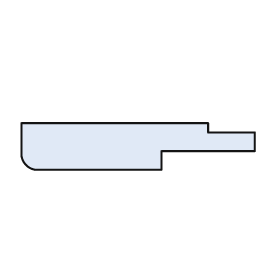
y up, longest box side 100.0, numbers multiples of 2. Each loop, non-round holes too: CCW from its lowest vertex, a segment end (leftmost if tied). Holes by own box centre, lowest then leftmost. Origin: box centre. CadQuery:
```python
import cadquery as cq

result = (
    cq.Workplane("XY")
    .moveTo(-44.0, -10.0)
    .lineTo(10.0, -10.0)
    .lineTo(10.0, -2.0)
    .lineTo(50.0, -2.0)
    .lineTo(50.0, 6.0)
    .lineTo(30.0, 6.0)
    .lineTo(30.0, 10.0)
    .lineTo(-50.0, 10.0)
    .lineTo(-50.0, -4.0)
    .threePointArc((-48.0, -8.0), (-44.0, -10.0))
    .close()
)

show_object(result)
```